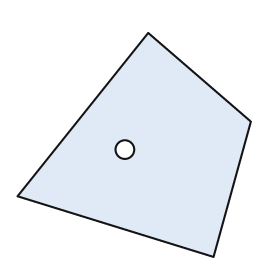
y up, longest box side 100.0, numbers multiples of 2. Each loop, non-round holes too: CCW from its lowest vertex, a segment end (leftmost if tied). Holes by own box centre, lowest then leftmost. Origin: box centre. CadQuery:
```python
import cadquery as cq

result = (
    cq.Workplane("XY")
    .moveTo(34.0, -48.0)
    .lineTo(50.0, 10.0)
    .lineTo(6.0, 48.0)
    .lineTo(-50.0, -22.0)
    .close()
    .moveTo(-4.0, -2.0)
    .circle(4.0)
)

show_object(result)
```